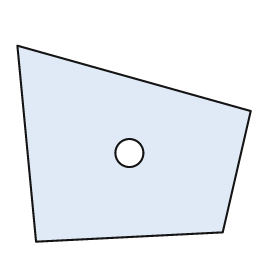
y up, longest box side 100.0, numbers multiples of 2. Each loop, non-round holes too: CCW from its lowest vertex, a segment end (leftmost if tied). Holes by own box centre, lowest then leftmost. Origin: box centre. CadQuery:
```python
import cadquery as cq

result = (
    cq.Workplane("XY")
    .moveTo(-42.0, -42.0)
    .lineTo(38.0, -38.0)
    .lineTo(50.0, 14.0)
    .lineTo(-50.0, 42.0)
    .close()
    .moveTo(-2.0, -4.0)
    .circle(6.0)
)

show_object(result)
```